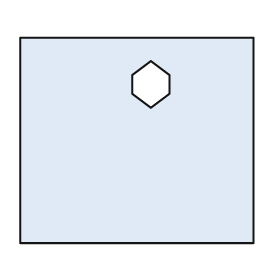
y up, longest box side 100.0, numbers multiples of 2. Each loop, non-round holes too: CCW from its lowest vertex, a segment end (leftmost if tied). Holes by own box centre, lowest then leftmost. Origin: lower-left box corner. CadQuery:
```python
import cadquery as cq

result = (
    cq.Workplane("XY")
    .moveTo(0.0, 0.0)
    .lineTo(100.0, 0.0)
    .lineTo(100.0, 88.0)
    .lineTo(0.0, 88.0)
    .close()
    .moveTo(56.0, 58.0)
    .lineTo(64.0, 64.0)
    .lineTo(64.0, 72.0)
    .lineTo(56.0, 78.0)
    .lineTo(48.0, 72.0)
    .lineTo(48.0, 64.0)
    .close()
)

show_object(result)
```